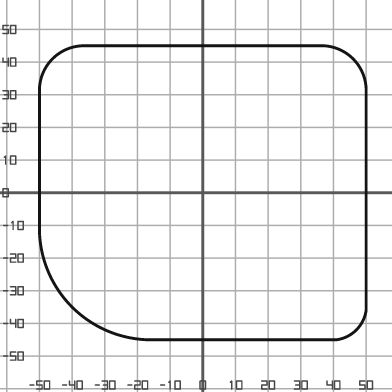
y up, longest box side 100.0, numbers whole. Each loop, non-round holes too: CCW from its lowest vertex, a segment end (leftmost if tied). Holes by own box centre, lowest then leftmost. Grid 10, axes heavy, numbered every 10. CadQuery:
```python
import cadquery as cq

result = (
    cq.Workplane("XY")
    .moveTo(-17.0, -45.0)
    .lineTo(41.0, -45.0)
    .threePointArc((47.0, -42.0), (50.0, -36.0))
    .lineTo(50.0, 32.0)
    .threePointArc((46.0, 41.0), (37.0, 45.0))
    .lineTo(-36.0, 45.0)
    .threePointArc((-46.0, 41.0), (-50.0, 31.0))
    .lineTo(-50.0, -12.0)
    .threePointArc((-40.0, -35.0), (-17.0, -45.0))
    .close()
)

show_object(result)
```